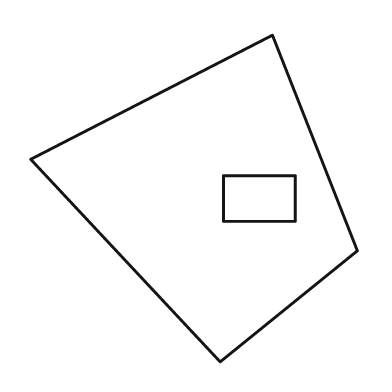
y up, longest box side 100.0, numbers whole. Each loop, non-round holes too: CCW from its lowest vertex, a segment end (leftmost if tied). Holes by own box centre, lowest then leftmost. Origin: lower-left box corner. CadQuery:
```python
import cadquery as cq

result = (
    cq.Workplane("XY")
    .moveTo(58.0, 0.0)
    .lineTo(100.0, 34.0)
    .lineTo(74.0, 100.0)
    .lineTo(0.0, 62.0)
    .close()
    .moveTo(59.0, 43.0)
    .lineTo(81.0, 43.0)
    .lineTo(81.0, 57.0)
    .lineTo(59.0, 57.0)
    .close()
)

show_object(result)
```